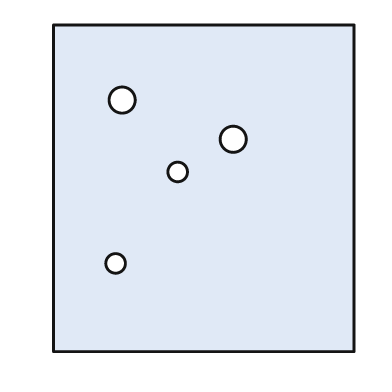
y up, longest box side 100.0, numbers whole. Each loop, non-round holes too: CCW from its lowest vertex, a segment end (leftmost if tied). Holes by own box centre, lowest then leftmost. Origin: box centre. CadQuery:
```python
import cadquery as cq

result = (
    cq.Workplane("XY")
    .moveTo(-46.0, -50.0)
    .lineTo(46.0, -50.0)
    .lineTo(46.0, 50.0)
    .lineTo(-46.0, 50.0)
    .close()
    .moveTo(-27.0, -23.0)
    .circle(3.0)
    .moveTo(-8.0, 5.0)
    .circle(3.0)
    .moveTo(9.0, 15.0)
    .circle(4.0)
    .moveTo(-25.0, 27.0)
    .circle(4.0)
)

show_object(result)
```